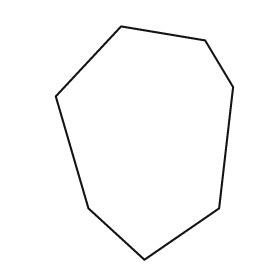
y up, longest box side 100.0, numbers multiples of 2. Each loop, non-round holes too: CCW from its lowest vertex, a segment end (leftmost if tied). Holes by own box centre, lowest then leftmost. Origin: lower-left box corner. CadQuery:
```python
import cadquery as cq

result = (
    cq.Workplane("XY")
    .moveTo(38.0, 0.0)
    .lineTo(70.0, 22.0)
    .lineTo(76.0, 74.0)
    .lineTo(64.0, 94.0)
    .lineTo(28.0, 100.0)
    .lineTo(0.0, 70.0)
    .lineTo(14.0, 22.0)
    .close()
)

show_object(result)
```